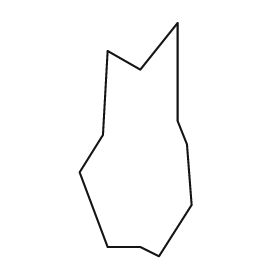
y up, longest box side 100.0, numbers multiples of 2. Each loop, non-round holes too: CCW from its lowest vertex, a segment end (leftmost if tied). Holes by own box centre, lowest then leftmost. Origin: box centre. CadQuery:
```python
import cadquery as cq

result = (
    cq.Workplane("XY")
    .moveTo(10.0, -50.0)
    .lineTo(24.0, -28.0)
    .lineTo(22.0, -2.0)
    .lineTo(18.0, 8.0)
    .lineTo(18.0, 50.0)
    .lineTo(2.0, 30.0)
    .lineTo(-12.0, 38.0)
    .lineTo(-14.0, 2.0)
    .lineTo(-24.0, -14.0)
    .lineTo(-12.0, -46.0)
    .lineTo(2.0, -46.0)
    .close()
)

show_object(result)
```